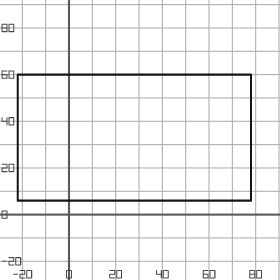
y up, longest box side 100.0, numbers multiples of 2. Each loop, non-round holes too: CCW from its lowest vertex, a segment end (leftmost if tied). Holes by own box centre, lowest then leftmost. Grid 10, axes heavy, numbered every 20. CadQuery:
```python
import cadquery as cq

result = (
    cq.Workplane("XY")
    .moveTo(-22.0, 6.0)
    .lineTo(78.0, 6.0)
    .lineTo(78.0, 60.0)
    .lineTo(-22.0, 60.0)
    .close()
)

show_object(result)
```